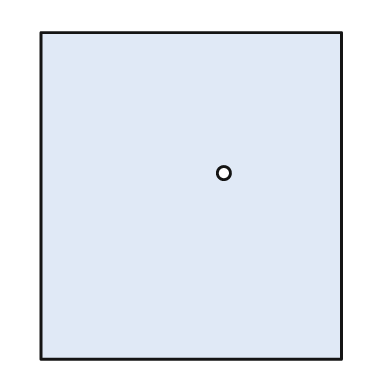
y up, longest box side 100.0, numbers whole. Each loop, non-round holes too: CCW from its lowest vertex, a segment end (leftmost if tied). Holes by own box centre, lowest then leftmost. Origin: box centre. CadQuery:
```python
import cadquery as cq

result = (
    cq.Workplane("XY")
    .moveTo(-46.0, -50.0)
    .lineTo(46.0, -50.0)
    .lineTo(46.0, 50.0)
    .lineTo(-46.0, 50.0)
    .close()
    .moveTo(10.0, 7.0)
    .circle(2.0)
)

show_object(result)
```